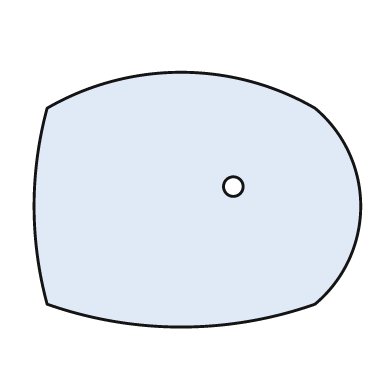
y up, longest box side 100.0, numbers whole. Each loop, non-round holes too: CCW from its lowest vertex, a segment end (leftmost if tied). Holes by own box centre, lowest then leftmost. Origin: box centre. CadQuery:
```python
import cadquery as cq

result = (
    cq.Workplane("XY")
    .moveTo(-46.0, -32.0)
    .threePointArc((-5.0, -39.0), (36.0, -32.0))
    .threePointArc((50.0, -2.0), (36.0, 28.0))
    .threePointArc((-5.0, 39.0), (-46.0, 28.0))
    .threePointArc((-50.0, -2.0), (-46.0, -32.0))
    .close()
    .moveTo(11.0, 4.0)
    .circle(3.0)
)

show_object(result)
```